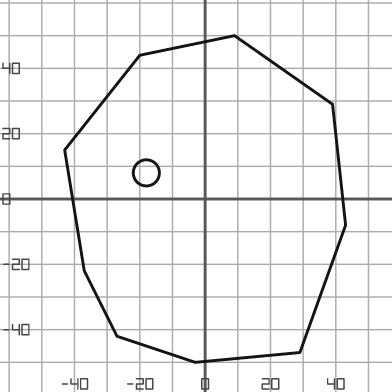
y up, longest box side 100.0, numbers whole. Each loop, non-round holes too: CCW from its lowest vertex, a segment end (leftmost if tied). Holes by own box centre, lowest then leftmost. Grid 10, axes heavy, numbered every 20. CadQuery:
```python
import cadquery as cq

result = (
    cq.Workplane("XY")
    .moveTo(-3.0, -50.0)
    .lineTo(29.0, -47.0)
    .lineTo(43.0, -8.0)
    .lineTo(39.0, 29.0)
    .lineTo(9.0, 50.0)
    .lineTo(-20.0, 44.0)
    .lineTo(-43.0, 15.0)
    .lineTo(-37.0, -22.0)
    .lineTo(-27.0, -42.0)
    .close()
    .moveTo(-18.0, 8.0)
    .circle(4.0)
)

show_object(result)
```